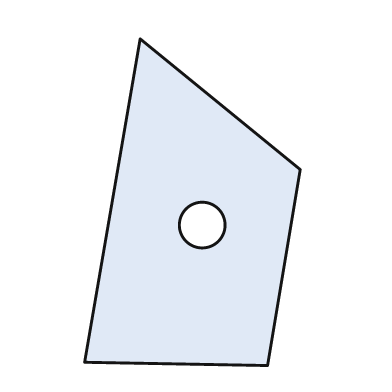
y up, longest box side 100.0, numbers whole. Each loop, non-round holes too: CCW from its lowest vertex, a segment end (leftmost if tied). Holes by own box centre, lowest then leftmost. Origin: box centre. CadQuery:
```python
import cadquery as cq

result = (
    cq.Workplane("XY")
    .moveTo(23.0, -50.0)
    .lineTo(33.0, 10.0)
    .lineTo(-16.0, 50.0)
    .lineTo(-33.0, -49.0)
    .close()
    .moveTo(3.0, -7.0)
    .circle(7.0)
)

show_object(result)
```